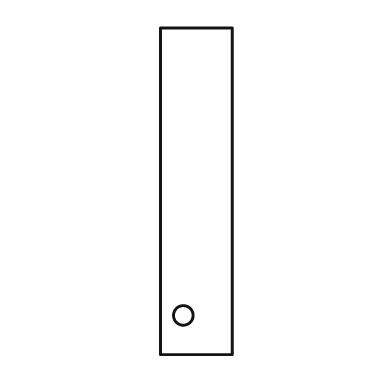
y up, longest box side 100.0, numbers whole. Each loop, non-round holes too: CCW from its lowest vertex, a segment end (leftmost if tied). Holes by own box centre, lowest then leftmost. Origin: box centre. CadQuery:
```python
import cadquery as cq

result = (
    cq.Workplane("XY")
    .moveTo(-11.0, -50.0)
    .lineTo(11.0, -50.0)
    .lineTo(11.0, 50.0)
    .lineTo(-11.0, 50.0)
    .close()
    .moveTo(-4.0, -38.0)
    .circle(3.0)
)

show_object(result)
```